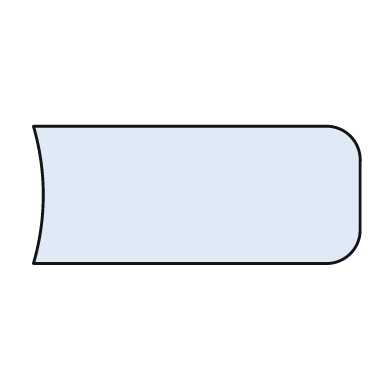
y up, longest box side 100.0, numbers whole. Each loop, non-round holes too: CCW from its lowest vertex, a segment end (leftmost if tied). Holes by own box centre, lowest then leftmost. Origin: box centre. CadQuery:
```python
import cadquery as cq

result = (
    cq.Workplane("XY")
    .moveTo(-50.0, -21.0)
    .lineTo(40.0, -21.0)
    .threePointArc((47.0, -18.0), (50.0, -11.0))
    .lineTo(50.0, 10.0)
    .threePointArc((47.0, 18.0), (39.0, 21.0))
    .lineTo(-50.0, 21.0)
    .threePointArc((-47.0, 0.0), (-50.0, -21.0))
    .close()
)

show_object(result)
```